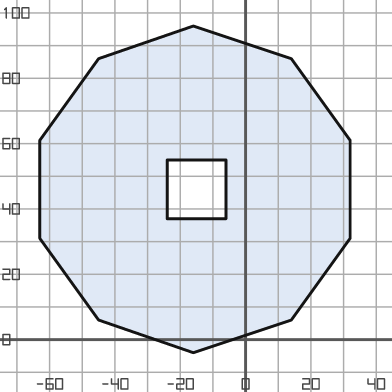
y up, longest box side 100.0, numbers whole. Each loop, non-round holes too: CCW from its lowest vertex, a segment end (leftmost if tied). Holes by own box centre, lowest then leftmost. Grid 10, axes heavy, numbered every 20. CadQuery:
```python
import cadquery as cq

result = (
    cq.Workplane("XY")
    .moveTo(-16.0, -4.0)
    .lineTo(14.0, 6.0)
    .lineTo(32.0, 31.0)
    .lineTo(32.0, 61.0)
    .lineTo(14.0, 86.0)
    .lineTo(-16.0, 96.0)
    .lineTo(-45.0, 86.0)
    .lineTo(-63.0, 61.0)
    .lineTo(-63.0, 31.0)
    .lineTo(-45.0, 6.0)
    .close()
    .moveTo(-24.0, 37.0)
    .lineTo(-6.0, 37.0)
    .lineTo(-6.0, 55.0)
    .lineTo(-24.0, 55.0)
    .close()
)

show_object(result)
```